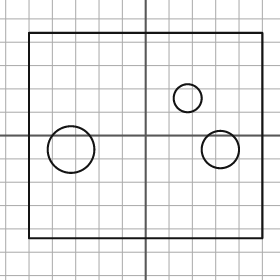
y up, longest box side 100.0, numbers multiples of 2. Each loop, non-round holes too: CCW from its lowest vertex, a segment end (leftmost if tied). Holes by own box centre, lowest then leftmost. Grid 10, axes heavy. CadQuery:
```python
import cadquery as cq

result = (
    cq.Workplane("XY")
    .moveTo(-50.0, -44.0)
    .lineTo(50.0, -44.0)
    .lineTo(50.0, 44.0)
    .lineTo(-50.0, 44.0)
    .close()
    .moveTo(-32.0, -6.0)
    .circle(10.0)
    .moveTo(32.0, -6.0)
    .circle(8.0)
    .moveTo(18.0, 16.0)
    .circle(6.0)
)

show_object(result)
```